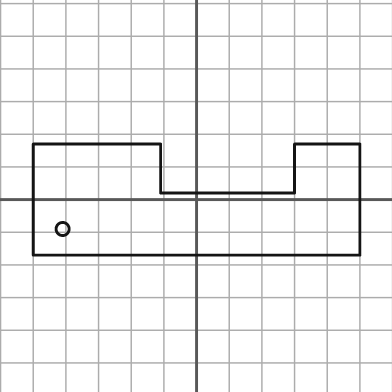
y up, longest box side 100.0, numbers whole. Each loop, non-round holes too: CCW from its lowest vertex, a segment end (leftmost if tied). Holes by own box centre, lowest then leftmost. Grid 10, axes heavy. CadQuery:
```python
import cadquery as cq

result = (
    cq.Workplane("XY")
    .moveTo(-50.0, -17.0)
    .lineTo(50.0, -17.0)
    .lineTo(50.0, 17.0)
    .lineTo(30.0, 17.0)
    .lineTo(30.0, 2.0)
    .lineTo(-11.0, 2.0)
    .lineTo(-11.0, 17.0)
    .lineTo(-50.0, 17.0)
    .close()
    .moveTo(-41.0, -9.0)
    .circle(2.0)
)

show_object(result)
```